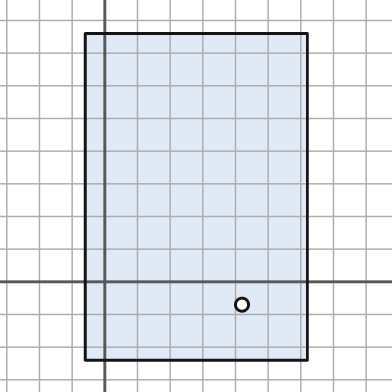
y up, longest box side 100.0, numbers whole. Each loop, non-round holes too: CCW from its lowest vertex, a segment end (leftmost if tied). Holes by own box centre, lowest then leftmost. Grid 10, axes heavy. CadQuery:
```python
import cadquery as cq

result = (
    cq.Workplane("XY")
    .moveTo(-6.0, -24.0)
    .lineTo(62.0, -24.0)
    .lineTo(62.0, 76.0)
    .lineTo(-6.0, 76.0)
    .close()
    .moveTo(42.0, -7.0)
    .circle(2.0)
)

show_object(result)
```